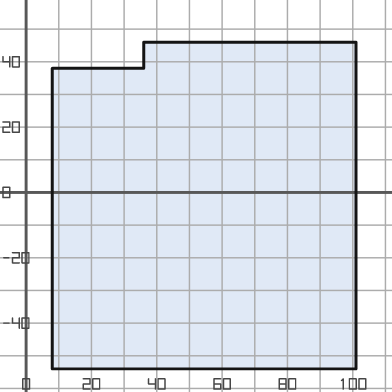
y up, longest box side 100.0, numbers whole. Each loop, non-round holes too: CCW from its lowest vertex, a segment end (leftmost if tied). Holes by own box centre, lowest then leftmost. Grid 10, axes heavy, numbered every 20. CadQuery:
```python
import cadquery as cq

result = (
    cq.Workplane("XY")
    .moveTo(8.0, -54.0)
    .lineTo(101.0, -54.0)
    .lineTo(101.0, 46.0)
    .lineTo(36.0, 46.0)
    .lineTo(36.0, 38.0)
    .lineTo(8.0, 38.0)
    .close()
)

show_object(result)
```